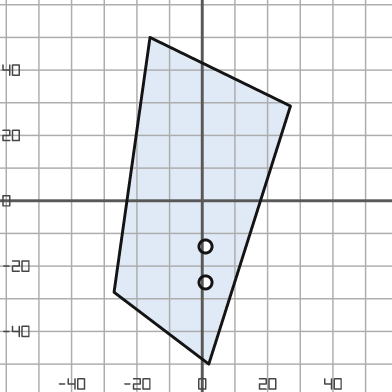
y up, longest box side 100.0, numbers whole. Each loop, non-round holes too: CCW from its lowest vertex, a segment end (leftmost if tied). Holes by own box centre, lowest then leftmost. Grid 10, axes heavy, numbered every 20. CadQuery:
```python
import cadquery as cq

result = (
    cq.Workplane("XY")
    .moveTo(2.0, -50.0)
    .lineTo(27.0, 29.0)
    .lineTo(-16.0, 50.0)
    .lineTo(-27.0, -28.0)
    .close()
    .moveTo(1.0, -25.0)
    .circle(2.0)
    .moveTo(1.0, -14.0)
    .circle(2.0)
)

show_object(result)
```